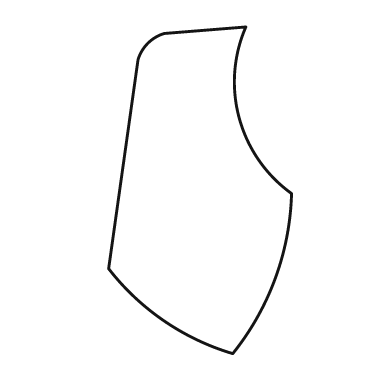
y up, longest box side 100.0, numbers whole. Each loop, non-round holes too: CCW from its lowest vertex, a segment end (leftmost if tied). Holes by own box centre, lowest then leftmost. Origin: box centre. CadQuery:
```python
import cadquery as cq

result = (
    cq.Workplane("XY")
    .moveTo(10.0, -50.0)
    .threePointArc((23.0, -27.0), (28.0, -1.0))
    .threePointArc((12.0, 22.0), (14.0, 50.0))
    .lineTo(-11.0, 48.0)
    .threePointArc((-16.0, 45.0), (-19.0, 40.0))
    .lineTo(-28.0, -24.0)
    .threePointArc((-11.0, -40.0), (10.0, -50.0))
    .close()
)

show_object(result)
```